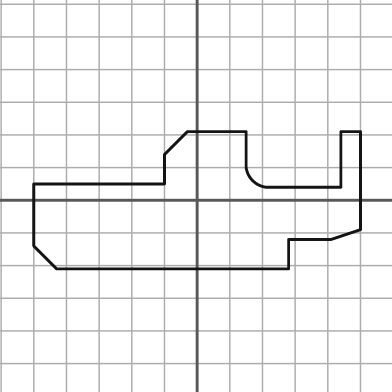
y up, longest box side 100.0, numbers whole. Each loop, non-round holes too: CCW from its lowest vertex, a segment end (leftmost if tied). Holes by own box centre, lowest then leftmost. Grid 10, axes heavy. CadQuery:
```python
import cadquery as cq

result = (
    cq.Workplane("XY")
    .moveTo(-43.0, -21.0)
    .lineTo(28.0, -21.0)
    .lineTo(28.0, -12.0)
    .lineTo(41.0, -12.0)
    .lineTo(50.0, -9.0)
    .lineTo(50.0, 21.0)
    .lineTo(44.0, 21.0)
    .lineTo(44.0, 4.0)
    .lineTo(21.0, 4.0)
    .threePointArc((17.0, 6.0), (15.0, 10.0))
    .lineTo(15.0, 21.0)
    .lineTo(-3.0, 21.0)
    .lineTo(-10.0, 14.0)
    .lineTo(-10.0, 5.0)
    .lineTo(-50.0, 5.0)
    .lineTo(-50.0, -14.0)
    .close()
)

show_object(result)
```